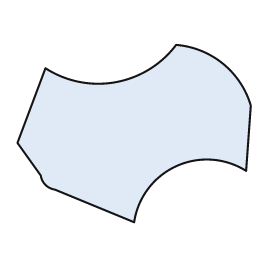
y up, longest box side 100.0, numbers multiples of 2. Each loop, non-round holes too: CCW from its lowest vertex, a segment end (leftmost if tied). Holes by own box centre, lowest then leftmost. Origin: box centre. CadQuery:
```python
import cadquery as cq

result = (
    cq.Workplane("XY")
    .moveTo(0.0, -38.0)
    .threePointArc((18.0, -14.0), (48.0, -16.0))
    .lineTo(50.0, 12.0)
    .threePointArc((38.0, 30.0), (18.0, 38.0))
    .threePointArc((-8.0, 22.0), (-38.0, 28.0))
    .lineTo(-50.0, -4.0)
    .lineTo(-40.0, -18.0)
    .threePointArc((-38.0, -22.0), (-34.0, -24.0))
    .close()
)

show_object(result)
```